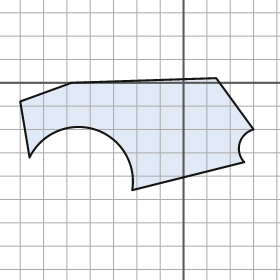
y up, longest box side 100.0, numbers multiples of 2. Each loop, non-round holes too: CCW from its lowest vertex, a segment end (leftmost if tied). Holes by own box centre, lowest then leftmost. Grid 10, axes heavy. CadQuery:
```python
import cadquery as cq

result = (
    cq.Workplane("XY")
    .moveTo(-22.0, -46.0)
    .lineTo(26.0, -34.0)
    .threePointArc((24.0, -26.0), (30.0, -20.0))
    .lineTo(14.0, 2.0)
    .lineTo(-48.0, 0.0)
    .lineTo(-70.0, -8.0)
    .lineTo(-66.0, -32.0)
    .threePointArc((-38.0, -20.0), (-22.0, -46.0))
    .close()
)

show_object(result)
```